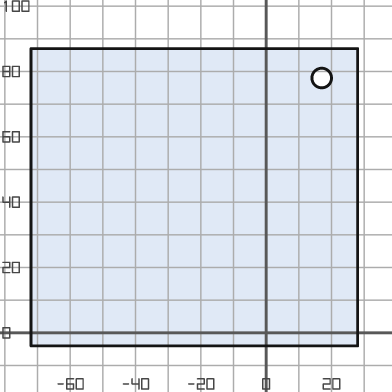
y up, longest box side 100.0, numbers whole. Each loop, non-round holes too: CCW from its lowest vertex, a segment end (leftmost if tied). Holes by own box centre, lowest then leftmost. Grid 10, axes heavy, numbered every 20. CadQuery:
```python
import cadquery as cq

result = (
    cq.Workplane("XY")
    .moveTo(-72.0, -4.0)
    .lineTo(28.0, -4.0)
    .lineTo(28.0, 87.0)
    .lineTo(-72.0, 87.0)
    .close()
    .moveTo(17.0, 78.0)
    .circle(3.0)
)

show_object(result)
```